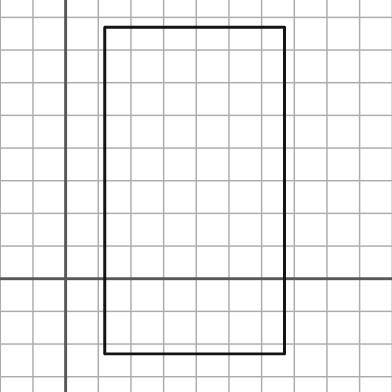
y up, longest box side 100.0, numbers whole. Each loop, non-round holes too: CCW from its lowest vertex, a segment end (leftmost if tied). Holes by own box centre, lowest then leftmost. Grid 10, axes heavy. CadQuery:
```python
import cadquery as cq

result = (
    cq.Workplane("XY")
    .moveTo(12.0, -23.0)
    .lineTo(67.0, -23.0)
    .lineTo(67.0, 77.0)
    .lineTo(12.0, 77.0)
    .close()
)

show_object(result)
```